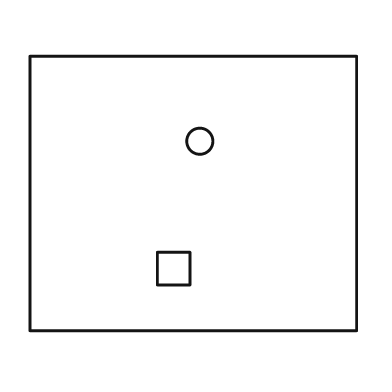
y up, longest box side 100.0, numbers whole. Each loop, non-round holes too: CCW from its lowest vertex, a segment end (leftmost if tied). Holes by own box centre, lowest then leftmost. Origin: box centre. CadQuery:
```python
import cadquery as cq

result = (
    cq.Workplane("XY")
    .moveTo(-50.0, -42.0)
    .lineTo(50.0, -42.0)
    .lineTo(50.0, 42.0)
    .lineTo(-50.0, 42.0)
    .close()
    .moveTo(-11.0, -28.0)
    .lineTo(-1.0, -28.0)
    .lineTo(-1.0, -18.0)
    .lineTo(-11.0, -18.0)
    .close()
    .moveTo(2.0, 16.0)
    .circle(4.0)
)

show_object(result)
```